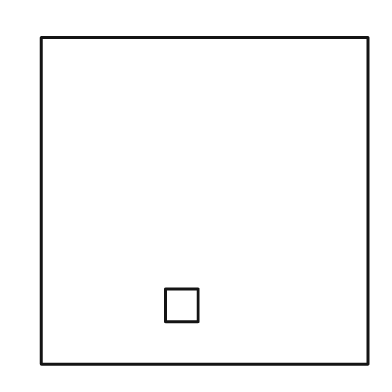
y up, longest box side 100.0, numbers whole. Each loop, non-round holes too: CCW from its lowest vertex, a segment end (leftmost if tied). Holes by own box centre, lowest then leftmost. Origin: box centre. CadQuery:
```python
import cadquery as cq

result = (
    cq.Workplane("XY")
    .moveTo(-50.0, -50.0)
    .lineTo(50.0, -50.0)
    .lineTo(50.0, 50.0)
    .lineTo(-50.0, 50.0)
    .close()
    .moveTo(-12.0, -37.0)
    .lineTo(-2.0, -37.0)
    .lineTo(-2.0, -27.0)
    .lineTo(-12.0, -27.0)
    .close()
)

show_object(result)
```